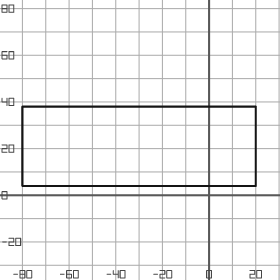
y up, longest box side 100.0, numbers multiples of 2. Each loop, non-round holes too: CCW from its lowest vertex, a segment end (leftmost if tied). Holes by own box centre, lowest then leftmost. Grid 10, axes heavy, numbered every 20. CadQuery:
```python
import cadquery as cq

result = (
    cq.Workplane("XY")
    .moveTo(-80.0, 4.0)
    .lineTo(20.0, 4.0)
    .lineTo(20.0, 38.0)
    .lineTo(-80.0, 38.0)
    .close()
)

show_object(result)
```